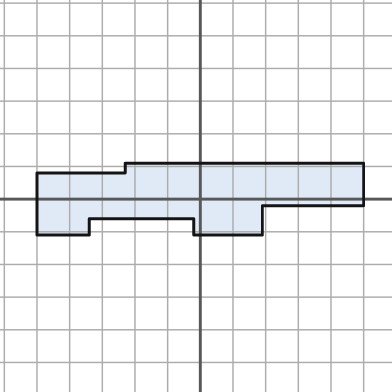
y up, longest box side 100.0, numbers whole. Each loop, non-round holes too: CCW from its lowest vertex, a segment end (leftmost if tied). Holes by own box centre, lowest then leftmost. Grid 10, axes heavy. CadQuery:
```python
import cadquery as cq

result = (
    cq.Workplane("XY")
    .moveTo(-50.0, -11.0)
    .lineTo(-34.0, -11.0)
    .lineTo(-34.0, -6.0)
    .lineTo(-2.0, -6.0)
    .lineTo(-2.0, -11.0)
    .lineTo(19.0, -11.0)
    .lineTo(19.0, -2.0)
    .lineTo(50.0, -2.0)
    .lineTo(50.0, 11.0)
    .lineTo(-23.0, 11.0)
    .lineTo(-23.0, 8.0)
    .lineTo(-50.0, 8.0)
    .close()
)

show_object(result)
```